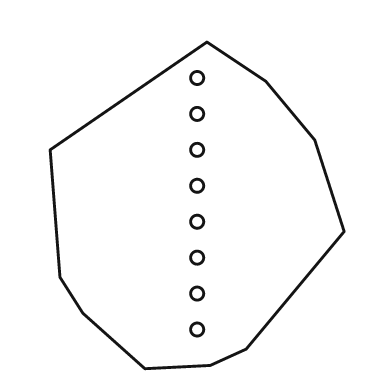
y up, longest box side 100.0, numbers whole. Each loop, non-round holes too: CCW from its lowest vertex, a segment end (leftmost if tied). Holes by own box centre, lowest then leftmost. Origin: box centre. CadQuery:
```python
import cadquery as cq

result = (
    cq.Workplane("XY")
    .moveTo(-16.0, -50.0)
    .lineTo(4.0, -49.0)
    .lineTo(15.0, -44.0)
    .lineTo(45.0, -8.0)
    .lineTo(36.0, 20.0)
    .lineTo(21.0, 38.0)
    .lineTo(3.0, 50.0)
    .lineTo(-45.0, 17.0)
    .lineTo(-42.0, -22.0)
    .lineTo(-35.0, -33.0)
    .close()
    .moveTo(0.0, -38.0)
    .circle(2.0)
    .moveTo(0.0, -27.0)
    .circle(2.0)
    .moveTo(0.0, -16.0)
    .circle(2.0)
    .moveTo(0.0, -5.0)
    .circle(2.0)
    .moveTo(0.0, 6.0)
    .circle(2.0)
    .moveTo(0.0, 17.0)
    .circle(2.0)
    .moveTo(0.0, 28.0)
    .circle(2.0)
    .moveTo(0.0, 39.0)
    .circle(2.0)
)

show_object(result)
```